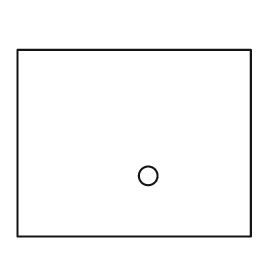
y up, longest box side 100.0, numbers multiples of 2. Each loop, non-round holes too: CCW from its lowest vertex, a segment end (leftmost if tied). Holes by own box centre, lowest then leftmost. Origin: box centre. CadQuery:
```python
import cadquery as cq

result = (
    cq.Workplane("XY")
    .moveTo(-50.0, -40.0)
    .lineTo(50.0, -40.0)
    .lineTo(50.0, 40.0)
    .lineTo(-50.0, 40.0)
    .close()
    .moveTo(6.0, -14.0)
    .circle(4.0)
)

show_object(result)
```